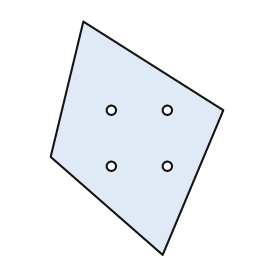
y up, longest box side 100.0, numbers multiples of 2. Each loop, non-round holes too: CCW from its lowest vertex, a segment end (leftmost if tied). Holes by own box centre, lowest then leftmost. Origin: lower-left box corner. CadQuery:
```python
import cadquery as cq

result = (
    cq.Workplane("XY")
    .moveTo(48.0, 0.0)
    .lineTo(74.0, 62.0)
    .lineTo(14.0, 100.0)
    .lineTo(0.0, 42.0)
    .close()
    .moveTo(26.0, 38.0)
    .circle(2.0)
    .moveTo(50.0, 38.0)
    .circle(2.0)
    .moveTo(26.0, 62.0)
    .circle(2.0)
    .moveTo(50.0, 62.0)
    .circle(2.0)
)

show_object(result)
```